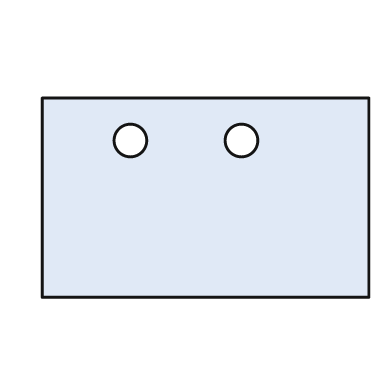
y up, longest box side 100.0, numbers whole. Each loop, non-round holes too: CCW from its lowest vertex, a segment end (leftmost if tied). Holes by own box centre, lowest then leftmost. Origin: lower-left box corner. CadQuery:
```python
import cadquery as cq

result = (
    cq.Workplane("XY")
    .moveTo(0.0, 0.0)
    .lineTo(100.0, 0.0)
    .lineTo(100.0, 61.0)
    .lineTo(0.0, 61.0)
    .close()
    .moveTo(27.0, 48.0)
    .circle(5.0)
    .moveTo(61.0, 48.0)
    .circle(5.0)
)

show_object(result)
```